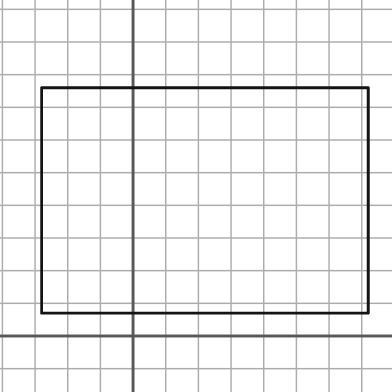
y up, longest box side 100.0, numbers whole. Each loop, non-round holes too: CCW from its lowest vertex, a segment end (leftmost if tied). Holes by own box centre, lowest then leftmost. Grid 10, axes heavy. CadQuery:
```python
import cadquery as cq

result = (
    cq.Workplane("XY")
    .moveTo(-28.0, 7.0)
    .lineTo(72.0, 7.0)
    .lineTo(72.0, 76.0)
    .lineTo(-28.0, 76.0)
    .close()
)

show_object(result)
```